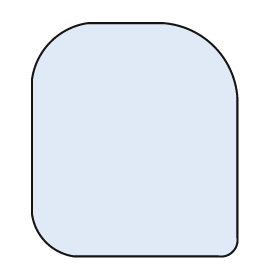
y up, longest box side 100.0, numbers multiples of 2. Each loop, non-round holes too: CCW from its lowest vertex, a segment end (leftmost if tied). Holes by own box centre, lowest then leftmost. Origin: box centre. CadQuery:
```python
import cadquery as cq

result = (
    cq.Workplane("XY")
    .moveTo(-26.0, -50.0)
    .lineTo(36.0, -50.0)
    .threePointArc((42.0, -48.0), (44.0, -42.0))
    .lineTo(44.0, 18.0)
    .threePointArc((34.0, 40.0), (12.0, 50.0))
    .lineTo(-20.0, 50.0)
    .threePointArc((-36.0, 42.0), (-44.0, 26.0))
    .lineTo(-44.0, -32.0)
    .threePointArc((-38.0, -44.0), (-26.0, -50.0))
    .close()
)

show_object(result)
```